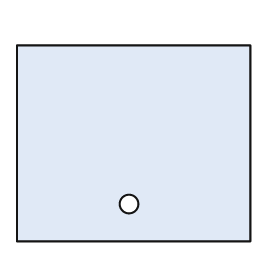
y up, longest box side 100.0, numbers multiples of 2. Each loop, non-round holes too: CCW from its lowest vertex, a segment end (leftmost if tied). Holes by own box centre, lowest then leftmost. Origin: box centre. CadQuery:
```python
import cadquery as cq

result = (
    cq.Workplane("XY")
    .moveTo(-50.0, -42.0)
    .lineTo(50.0, -42.0)
    .lineTo(50.0, 42.0)
    .lineTo(-50.0, 42.0)
    .close()
    .moveTo(-2.0, -26.0)
    .circle(4.0)
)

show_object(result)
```